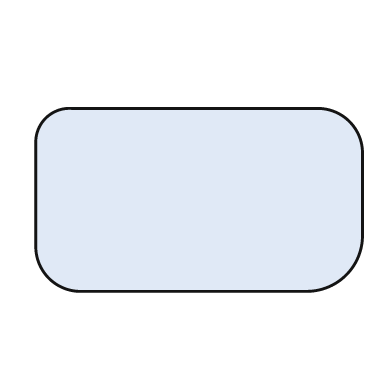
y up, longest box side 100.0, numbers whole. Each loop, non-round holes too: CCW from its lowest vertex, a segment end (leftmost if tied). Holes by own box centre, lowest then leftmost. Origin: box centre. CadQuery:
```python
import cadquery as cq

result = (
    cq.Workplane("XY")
    .moveTo(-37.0, -28.0)
    .lineTo(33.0, -28.0)
    .threePointArc((45.0, -23.0), (50.0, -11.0))
    .lineTo(50.0, 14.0)
    .threePointArc((46.0, 24.0), (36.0, 28.0))
    .lineTo(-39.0, 28.0)
    .threePointArc((-47.0, 25.0), (-50.0, 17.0))
    .lineTo(-50.0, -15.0)
    .threePointArc((-46.0, -24.0), (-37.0, -28.0))
    .close()
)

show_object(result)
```